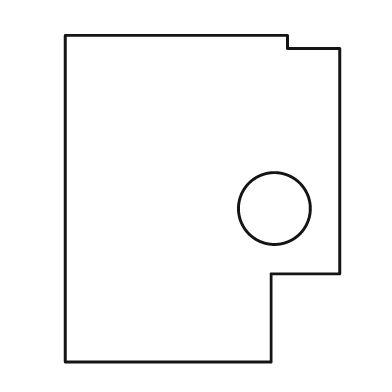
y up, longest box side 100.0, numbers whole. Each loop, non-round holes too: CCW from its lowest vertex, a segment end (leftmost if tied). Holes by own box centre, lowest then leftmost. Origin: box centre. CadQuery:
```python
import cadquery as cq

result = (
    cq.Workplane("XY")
    .moveTo(-42.0, -50.0)
    .lineTo(21.0, -50.0)
    .lineTo(21.0, -23.0)
    .lineTo(42.0, -23.0)
    .lineTo(42.0, 46.0)
    .lineTo(26.0, 46.0)
    .lineTo(26.0, 50.0)
    .lineTo(-42.0, 50.0)
    .close()
    .moveTo(22.0, -3.0)
    .circle(11.0)
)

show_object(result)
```